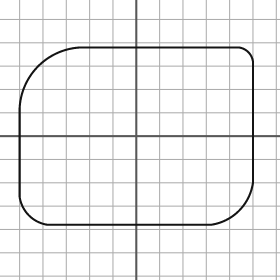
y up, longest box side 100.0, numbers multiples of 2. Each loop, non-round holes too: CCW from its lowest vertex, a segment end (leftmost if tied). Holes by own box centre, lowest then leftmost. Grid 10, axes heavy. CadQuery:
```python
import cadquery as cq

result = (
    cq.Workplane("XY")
    .moveTo(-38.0, -38.0)
    .lineTo(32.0, -38.0)
    .threePointArc((44.0, -32.0), (50.0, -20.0))
    .lineTo(50.0, 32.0)
    .threePointArc((48.0, 36.0), (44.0, 38.0))
    .lineTo(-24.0, 38.0)
    .threePointArc((-42.0, 30.0), (-50.0, 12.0))
    .lineTo(-50.0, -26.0)
    .threePointArc((-46.0, -34.0), (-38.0, -38.0))
    .close()
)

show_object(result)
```